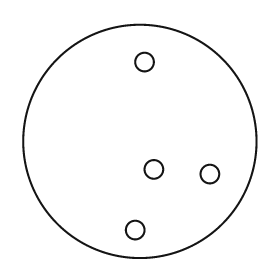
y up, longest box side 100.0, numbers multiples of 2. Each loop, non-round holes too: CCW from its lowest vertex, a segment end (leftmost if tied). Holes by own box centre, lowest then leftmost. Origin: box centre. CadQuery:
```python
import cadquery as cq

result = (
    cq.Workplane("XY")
    .moveTo(0.0, 0.0)
    .circle(50.0)
    .moveTo(-2.0, -38.0)
    .circle(4.0)
    .moveTo(30.0, -14.0)
    .circle(4.0)
    .moveTo(6.0, -12.0)
    .circle(4.0)
    .moveTo(2.0, 34.0)
    .circle(4.0)
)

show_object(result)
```